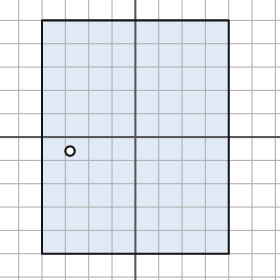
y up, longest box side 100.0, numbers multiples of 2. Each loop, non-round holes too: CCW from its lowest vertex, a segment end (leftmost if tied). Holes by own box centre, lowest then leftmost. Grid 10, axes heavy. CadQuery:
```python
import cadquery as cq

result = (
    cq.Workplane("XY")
    .moveTo(-40.0, -50.0)
    .lineTo(40.0, -50.0)
    .lineTo(40.0, 50.0)
    .lineTo(-40.0, 50.0)
    .close()
    .moveTo(-28.0, -6.0)
    .circle(2.0)
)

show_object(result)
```